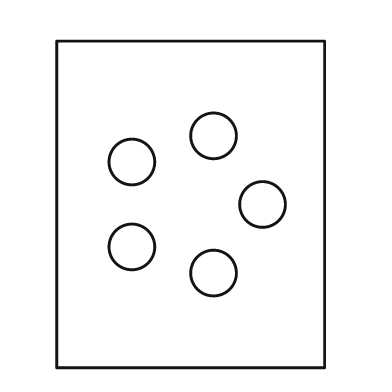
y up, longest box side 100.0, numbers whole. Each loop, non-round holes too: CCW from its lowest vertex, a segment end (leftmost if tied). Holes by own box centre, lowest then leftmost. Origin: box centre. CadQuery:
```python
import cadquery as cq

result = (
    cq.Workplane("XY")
    .moveTo(-41.0, -50.0)
    .lineTo(41.0, -50.0)
    .lineTo(41.0, 50.0)
    .lineTo(-41.0, 50.0)
    .close()
    .moveTo(7.0, -21.0)
    .circle(7.0)
    .moveTo(-18.0, -13.0)
    .circle(7.0)
    .moveTo(22.0, 0.0)
    .circle(7.0)
    .moveTo(-18.0, 13.0)
    .circle(7.0)
    .moveTo(7.0, 21.0)
    .circle(7.0)
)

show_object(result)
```